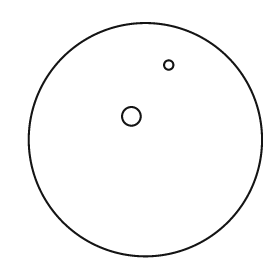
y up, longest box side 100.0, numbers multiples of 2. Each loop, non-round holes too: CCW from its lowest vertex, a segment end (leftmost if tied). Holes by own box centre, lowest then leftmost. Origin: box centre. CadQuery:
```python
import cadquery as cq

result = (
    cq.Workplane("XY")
    .moveTo(0.0, 0.0)
    .circle(50.0)
    .moveTo(-6.0, 10.0)
    .circle(4.0)
    .moveTo(10.0, 32.0)
    .circle(2.0)
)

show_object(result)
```